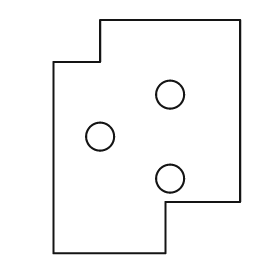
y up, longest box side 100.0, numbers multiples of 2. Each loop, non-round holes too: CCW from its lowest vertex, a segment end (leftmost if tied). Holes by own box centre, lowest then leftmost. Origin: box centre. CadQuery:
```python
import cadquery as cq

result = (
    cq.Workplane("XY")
    .moveTo(-40.0, -50.0)
    .lineTo(8.0, -50.0)
    .lineTo(8.0, -28.0)
    .lineTo(40.0, -28.0)
    .lineTo(40.0, 50.0)
    .lineTo(-20.0, 50.0)
    .lineTo(-20.0, 32.0)
    .lineTo(-40.0, 32.0)
    .close()
    .moveTo(10.0, -18.0)
    .circle(6.0)
    .moveTo(-20.0, 0.0)
    .circle(6.0)
    .moveTo(10.0, 18.0)
    .circle(6.0)
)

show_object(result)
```